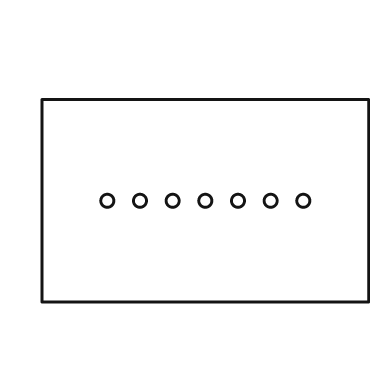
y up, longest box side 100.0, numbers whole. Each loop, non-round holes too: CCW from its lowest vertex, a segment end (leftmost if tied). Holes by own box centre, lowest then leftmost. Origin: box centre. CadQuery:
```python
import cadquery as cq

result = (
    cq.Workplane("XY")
    .moveTo(-50.0, -31.0)
    .lineTo(50.0, -31.0)
    .lineTo(50.0, 31.0)
    .lineTo(-50.0, 31.0)
    .close()
    .moveTo(-30.0, 0.0)
    .circle(2.0)
    .moveTo(-20.0, 0.0)
    .circle(2.0)
    .moveTo(-10.0, 0.0)
    .circle(2.0)
    .moveTo(0.0, 0.0)
    .circle(2.0)
    .moveTo(10.0, 0.0)
    .circle(2.0)
    .moveTo(20.0, 0.0)
    .circle(2.0)
    .moveTo(30.0, 0.0)
    .circle(2.0)
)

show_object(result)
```